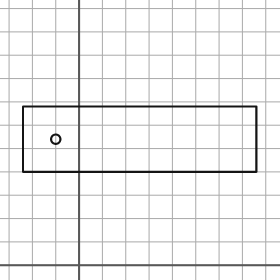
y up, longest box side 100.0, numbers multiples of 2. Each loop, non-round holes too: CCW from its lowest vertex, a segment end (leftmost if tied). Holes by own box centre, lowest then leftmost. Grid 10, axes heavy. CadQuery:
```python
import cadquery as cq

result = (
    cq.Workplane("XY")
    .moveTo(-24.0, 40.0)
    .lineTo(76.0, 40.0)
    .lineTo(76.0, 68.0)
    .lineTo(-24.0, 68.0)
    .close()
    .moveTo(-10.0, 54.0)
    .circle(2.0)
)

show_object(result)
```